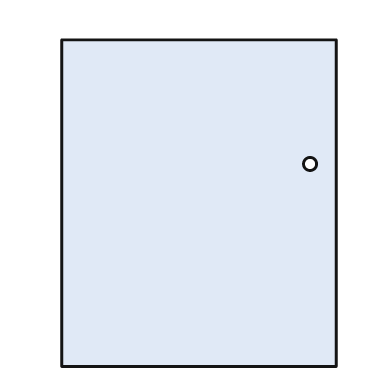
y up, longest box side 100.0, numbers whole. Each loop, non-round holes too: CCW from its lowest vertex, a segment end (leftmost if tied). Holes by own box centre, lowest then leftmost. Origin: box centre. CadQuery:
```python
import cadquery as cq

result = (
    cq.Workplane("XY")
    .moveTo(-42.0, -50.0)
    .lineTo(42.0, -50.0)
    .lineTo(42.0, 50.0)
    .lineTo(-42.0, 50.0)
    .close()
    .moveTo(34.0, 12.0)
    .circle(2.0)
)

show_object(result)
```